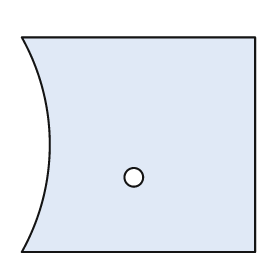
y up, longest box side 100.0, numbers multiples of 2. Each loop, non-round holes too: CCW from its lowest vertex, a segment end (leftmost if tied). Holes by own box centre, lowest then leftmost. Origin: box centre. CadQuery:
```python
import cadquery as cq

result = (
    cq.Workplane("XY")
    .moveTo(-50.0, -46.0)
    .lineTo(50.0, -46.0)
    .lineTo(50.0, 46.0)
    .lineTo(-50.0, 46.0)
    .threePointArc((-38.0, 0.0), (-50.0, -46.0))
    .close()
    .moveTo(-2.0, -14.0)
    .circle(4.0)
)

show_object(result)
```